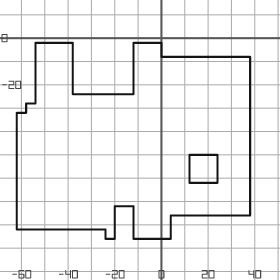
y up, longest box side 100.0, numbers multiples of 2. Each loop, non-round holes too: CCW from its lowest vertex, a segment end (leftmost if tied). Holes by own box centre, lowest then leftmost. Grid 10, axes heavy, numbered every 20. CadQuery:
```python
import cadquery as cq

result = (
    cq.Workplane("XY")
    .moveTo(-24.0, -86.0)
    .lineTo(-20.0, -86.0)
    .lineTo(-20.0, -72.0)
    .lineTo(-12.0, -72.0)
    .lineTo(-12.0, -86.0)
    .lineTo(4.0, -86.0)
    .lineTo(4.0, -76.0)
    .lineTo(38.0, -76.0)
    .lineTo(38.0, -8.0)
    .lineTo(0.0, -8.0)
    .lineTo(0.0, -2.0)
    .lineTo(-12.0, -2.0)
    .lineTo(-12.0, -24.0)
    .lineTo(-38.0, -24.0)
    .lineTo(-38.0, -2.0)
    .lineTo(-54.0, -2.0)
    .lineTo(-54.0, -28.0)
    .lineTo(-58.0, -28.0)
    .lineTo(-58.0, -32.0)
    .lineTo(-62.0, -32.0)
    .lineTo(-62.0, -82.0)
    .lineTo(-24.0, -82.0)
    .close()
    .moveTo(12.0, -62.0)
    .lineTo(24.0, -62.0)
    .lineTo(24.0, -50.0)
    .lineTo(12.0, -50.0)
    .close()
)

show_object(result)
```